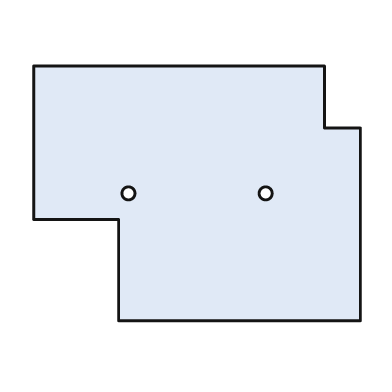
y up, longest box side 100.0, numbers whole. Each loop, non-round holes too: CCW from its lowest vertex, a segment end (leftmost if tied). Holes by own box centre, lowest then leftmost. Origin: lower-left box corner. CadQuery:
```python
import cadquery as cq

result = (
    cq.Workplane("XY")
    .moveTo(26.0, 0.0)
    .lineTo(100.0, 0.0)
    .lineTo(100.0, 59.0)
    .lineTo(89.0, 59.0)
    .lineTo(89.0, 78.0)
    .lineTo(0.0, 78.0)
    .lineTo(0.0, 31.0)
    .lineTo(26.0, 31.0)
    .close()
    .moveTo(29.0, 39.0)
    .circle(2.0)
    .moveTo(71.0, 39.0)
    .circle(2.0)
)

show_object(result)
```